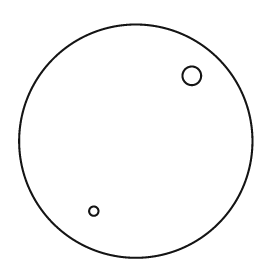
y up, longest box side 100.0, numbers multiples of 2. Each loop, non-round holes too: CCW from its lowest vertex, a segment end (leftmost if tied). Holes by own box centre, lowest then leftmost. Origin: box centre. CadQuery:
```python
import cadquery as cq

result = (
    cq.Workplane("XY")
    .moveTo(0.0, 0.0)
    .circle(50.0)
    .moveTo(-18.0, -30.0)
    .circle(2.0)
    .moveTo(24.0, 28.0)
    .circle(4.0)
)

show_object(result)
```